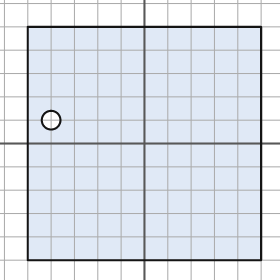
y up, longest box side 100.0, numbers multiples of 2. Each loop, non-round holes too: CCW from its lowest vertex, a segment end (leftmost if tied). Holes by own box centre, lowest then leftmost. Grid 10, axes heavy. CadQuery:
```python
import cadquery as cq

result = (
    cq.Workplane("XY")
    .moveTo(-50.0, -50.0)
    .lineTo(50.0, -50.0)
    .lineTo(50.0, 50.0)
    .lineTo(-50.0, 50.0)
    .close()
    .moveTo(-40.0, 10.0)
    .circle(4.0)
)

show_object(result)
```